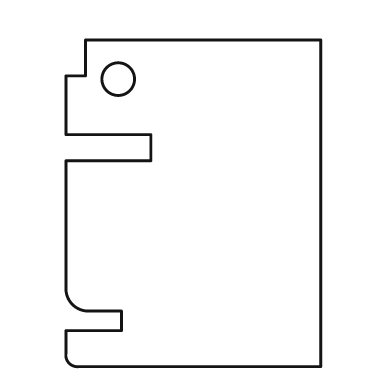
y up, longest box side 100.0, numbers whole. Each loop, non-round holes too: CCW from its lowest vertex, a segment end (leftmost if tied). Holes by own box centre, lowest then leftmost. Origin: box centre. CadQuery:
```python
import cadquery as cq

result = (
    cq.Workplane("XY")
    .moveTo(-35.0, -50.0)
    .lineTo(39.0, -50.0)
    .lineTo(39.0, 50.0)
    .lineTo(-33.0, 50.0)
    .lineTo(-33.0, 39.0)
    .lineTo(-39.0, 39.0)
    .lineTo(-39.0, 21.0)
    .lineTo(-13.0, 21.0)
    .lineTo(-13.0, 13.0)
    .lineTo(-39.0, 13.0)
    .lineTo(-39.0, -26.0)
    .threePointArc((-37.0, -31.0), (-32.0, -33.0))
    .lineTo(-22.0, -33.0)
    .lineTo(-22.0, -39.0)
    .lineTo(-39.0, -39.0)
    .lineTo(-39.0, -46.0)
    .threePointArc((-38.0, -49.0), (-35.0, -50.0))
    .close()
    .moveTo(-23.0, 38.0)
    .circle(5.0)
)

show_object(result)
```